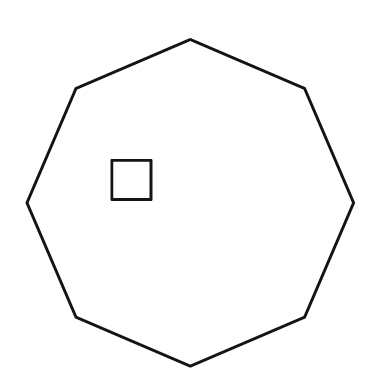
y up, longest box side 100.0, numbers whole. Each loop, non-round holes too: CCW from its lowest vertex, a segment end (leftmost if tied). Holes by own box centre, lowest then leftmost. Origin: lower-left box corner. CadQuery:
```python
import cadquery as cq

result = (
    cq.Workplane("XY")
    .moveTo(50.0, 0.0)
    .lineTo(85.0, 15.0)
    .lineTo(100.0, 50.0)
    .lineTo(85.0, 85.0)
    .lineTo(50.0, 100.0)
    .lineTo(15.0, 85.0)
    .lineTo(0.0, 50.0)
    .lineTo(15.0, 15.0)
    .close()
    .moveTo(26.0, 51.0)
    .lineTo(38.0, 51.0)
    .lineTo(38.0, 63.0)
    .lineTo(26.0, 63.0)
    .close()
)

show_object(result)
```